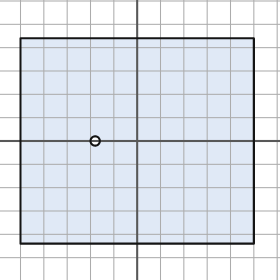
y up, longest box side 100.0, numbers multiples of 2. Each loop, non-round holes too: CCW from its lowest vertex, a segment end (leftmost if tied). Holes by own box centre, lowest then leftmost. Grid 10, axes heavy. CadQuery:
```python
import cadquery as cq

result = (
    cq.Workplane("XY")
    .moveTo(-50.0, -44.0)
    .lineTo(50.0, -44.0)
    .lineTo(50.0, 44.0)
    .lineTo(-50.0, 44.0)
    .close()
    .moveTo(-18.0, 0.0)
    .circle(2.0)
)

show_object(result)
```